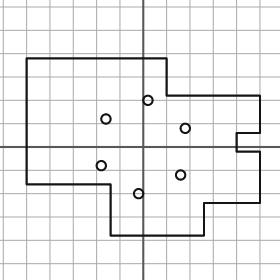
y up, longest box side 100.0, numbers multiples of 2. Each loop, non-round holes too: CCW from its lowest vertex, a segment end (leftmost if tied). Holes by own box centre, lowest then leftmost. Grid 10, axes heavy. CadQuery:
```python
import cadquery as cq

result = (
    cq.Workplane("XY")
    .moveTo(-14.0, -38.0)
    .lineTo(26.0, -38.0)
    .lineTo(26.0, -24.0)
    .lineTo(50.0, -24.0)
    .lineTo(50.0, -2.0)
    .lineTo(40.0, -2.0)
    .lineTo(40.0, 6.0)
    .lineTo(50.0, 6.0)
    .lineTo(50.0, 22.0)
    .lineTo(10.0, 22.0)
    .lineTo(10.0, 38.0)
    .lineTo(-50.0, 38.0)
    .lineTo(-50.0, -16.0)
    .lineTo(-14.0, -16.0)
    .close()
    .moveTo(-2.0, -20.0)
    .circle(2.0)
    .moveTo(16.0, -12.0)
    .circle(2.0)
    .moveTo(-18.0, -8.0)
    .circle(2.0)
    .moveTo(18.0, 8.0)
    .circle(2.0)
    .moveTo(-16.0, 12.0)
    .circle(2.0)
    .moveTo(2.0, 20.0)
    .circle(2.0)
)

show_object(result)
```